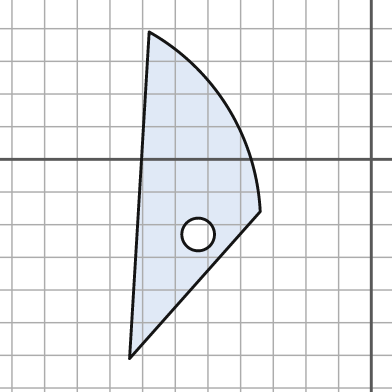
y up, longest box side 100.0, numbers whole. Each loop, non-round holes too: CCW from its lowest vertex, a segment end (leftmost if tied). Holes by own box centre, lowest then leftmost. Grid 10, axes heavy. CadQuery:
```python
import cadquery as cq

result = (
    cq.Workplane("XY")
    .moveTo(-74.0, -61.0)
    .lineTo(-34.0, -16.0)
    .threePointArc((-44.0, 16.0), (-68.0, 39.0))
    .close()
    .moveTo(-53.0, -23.0)
    .circle(5.0)
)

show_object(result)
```